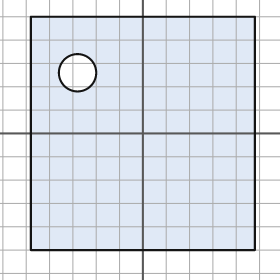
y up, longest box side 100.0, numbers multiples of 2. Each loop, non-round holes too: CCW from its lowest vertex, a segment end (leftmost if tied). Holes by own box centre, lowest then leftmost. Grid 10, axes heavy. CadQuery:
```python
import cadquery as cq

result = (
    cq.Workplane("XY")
    .moveTo(-48.0, -50.0)
    .lineTo(48.0, -50.0)
    .lineTo(48.0, 50.0)
    .lineTo(-48.0, 50.0)
    .close()
    .moveTo(-28.0, 26.0)
    .circle(8.0)
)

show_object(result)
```